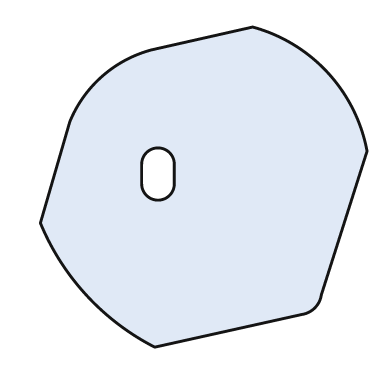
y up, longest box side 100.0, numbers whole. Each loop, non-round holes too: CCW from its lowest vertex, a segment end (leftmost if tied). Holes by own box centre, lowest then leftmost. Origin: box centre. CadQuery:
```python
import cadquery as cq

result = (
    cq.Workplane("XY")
    .moveTo(-15.0, -49.0)
    .lineTo(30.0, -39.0)
    .threePointArc((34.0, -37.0), (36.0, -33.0))
    .lineTo(50.0, 11.0)
    .threePointArc((38.0, 35.0), (15.0, 49.0))
    .lineTo(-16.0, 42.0)
    .threePointArc((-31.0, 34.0), (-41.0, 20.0))
    .lineTo(-50.0, -11.0)
    .threePointArc((-36.0, -33.0), (-15.0, -49.0))
    .close()
    .moveTo(-19.0, 1.0)
    .threePointArc((-14.0, -4.0), (-9.0, 1.0))
    .lineTo(-9.0, 7.0)
    .threePointArc((-14.0, 12.0), (-19.0, 7.0))
    .close()
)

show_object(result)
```